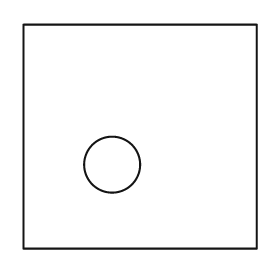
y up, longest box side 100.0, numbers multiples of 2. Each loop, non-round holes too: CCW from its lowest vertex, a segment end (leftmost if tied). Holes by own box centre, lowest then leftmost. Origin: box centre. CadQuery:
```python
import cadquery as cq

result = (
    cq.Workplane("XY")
    .moveTo(-50.0, -48.0)
    .lineTo(50.0, -48.0)
    .lineTo(50.0, 48.0)
    .lineTo(-50.0, 48.0)
    .close()
    .moveTo(-12.0, -12.0)
    .circle(12.0)
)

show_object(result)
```